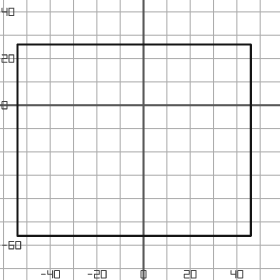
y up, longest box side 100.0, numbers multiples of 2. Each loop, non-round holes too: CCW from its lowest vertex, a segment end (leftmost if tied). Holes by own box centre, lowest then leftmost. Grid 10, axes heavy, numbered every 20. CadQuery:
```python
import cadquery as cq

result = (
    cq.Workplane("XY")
    .moveTo(-54.0, -56.0)
    .lineTo(46.0, -56.0)
    .lineTo(46.0, 26.0)
    .lineTo(-54.0, 26.0)
    .close()
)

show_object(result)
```